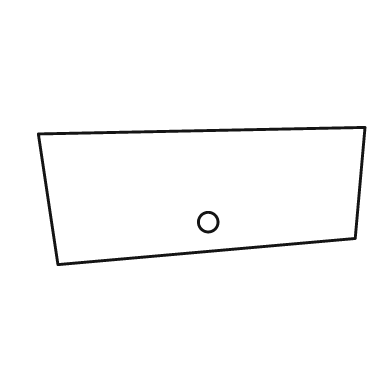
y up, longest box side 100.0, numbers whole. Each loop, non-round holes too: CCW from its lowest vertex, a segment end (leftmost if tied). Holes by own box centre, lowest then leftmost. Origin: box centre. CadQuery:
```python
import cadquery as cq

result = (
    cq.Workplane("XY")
    .moveTo(-44.0, -21.0)
    .lineTo(47.0, -13.0)
    .lineTo(50.0, 21.0)
    .lineTo(-50.0, 19.0)
    .close()
    .moveTo(2.0, -8.0)
    .circle(3.0)
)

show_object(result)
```